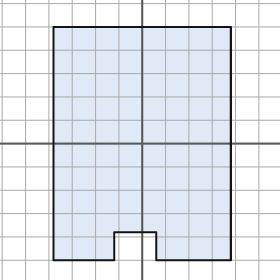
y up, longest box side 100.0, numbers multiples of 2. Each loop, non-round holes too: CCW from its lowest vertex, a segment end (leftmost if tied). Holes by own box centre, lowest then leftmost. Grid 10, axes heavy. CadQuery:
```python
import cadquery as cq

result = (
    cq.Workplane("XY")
    .moveTo(-38.0, -50.0)
    .lineTo(-12.0, -50.0)
    .lineTo(-12.0, -38.0)
    .lineTo(6.0, -38.0)
    .lineTo(6.0, -50.0)
    .lineTo(38.0, -50.0)
    .lineTo(38.0, 50.0)
    .lineTo(-38.0, 50.0)
    .close()
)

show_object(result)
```